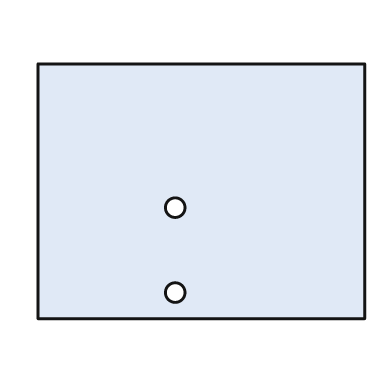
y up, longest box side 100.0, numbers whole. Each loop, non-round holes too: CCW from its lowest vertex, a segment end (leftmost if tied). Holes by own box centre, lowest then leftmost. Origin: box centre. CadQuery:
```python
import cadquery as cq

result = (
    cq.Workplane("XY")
    .moveTo(-50.0, -39.0)
    .lineTo(50.0, -39.0)
    .lineTo(50.0, 39.0)
    .lineTo(-50.0, 39.0)
    .close()
    .moveTo(-8.0, -31.0)
    .circle(3.0)
    .moveTo(-8.0, -5.0)
    .circle(3.0)
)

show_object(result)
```